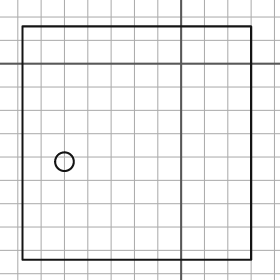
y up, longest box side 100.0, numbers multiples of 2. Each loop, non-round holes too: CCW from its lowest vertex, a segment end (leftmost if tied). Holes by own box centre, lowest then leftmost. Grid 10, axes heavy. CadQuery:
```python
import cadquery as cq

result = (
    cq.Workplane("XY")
    .moveTo(-68.0, -84.0)
    .lineTo(30.0, -84.0)
    .lineTo(30.0, 16.0)
    .lineTo(-68.0, 16.0)
    .close()
    .moveTo(-50.0, -42.0)
    .circle(4.0)
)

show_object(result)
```